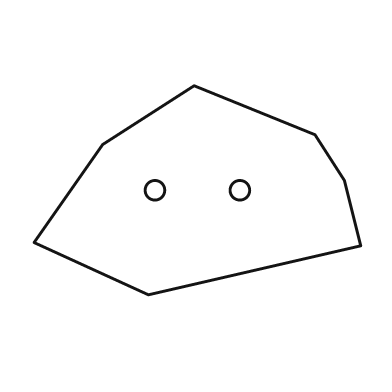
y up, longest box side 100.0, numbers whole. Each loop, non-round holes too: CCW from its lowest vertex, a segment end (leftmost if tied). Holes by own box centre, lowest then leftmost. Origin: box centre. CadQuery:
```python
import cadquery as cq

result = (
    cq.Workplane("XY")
    .moveTo(-15.0, -32.0)
    .lineTo(50.0, -17.0)
    .lineTo(45.0, 3.0)
    .lineTo(36.0, 17.0)
    .lineTo(-1.0, 32.0)
    .lineTo(-29.0, 14.0)
    .lineTo(-50.0, -16.0)
    .close()
    .moveTo(-13.0, 0.0)
    .circle(3.0)
    .moveTo(13.0, 0.0)
    .circle(3.0)
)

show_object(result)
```